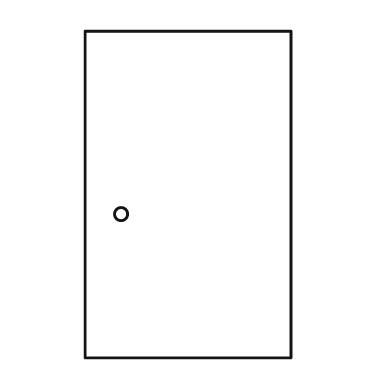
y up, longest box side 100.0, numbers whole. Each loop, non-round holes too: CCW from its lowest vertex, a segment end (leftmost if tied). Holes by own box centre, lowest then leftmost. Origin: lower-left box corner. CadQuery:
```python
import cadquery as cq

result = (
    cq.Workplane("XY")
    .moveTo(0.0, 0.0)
    .lineTo(63.0, 0.0)
    .lineTo(63.0, 100.0)
    .lineTo(0.0, 100.0)
    .close()
    .moveTo(11.0, 44.0)
    .circle(2.0)
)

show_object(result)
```